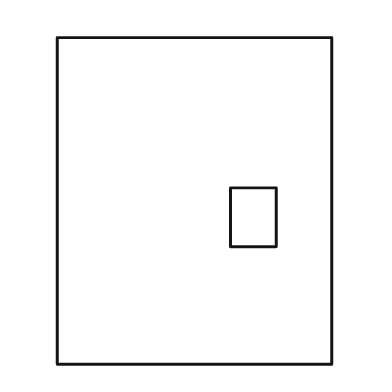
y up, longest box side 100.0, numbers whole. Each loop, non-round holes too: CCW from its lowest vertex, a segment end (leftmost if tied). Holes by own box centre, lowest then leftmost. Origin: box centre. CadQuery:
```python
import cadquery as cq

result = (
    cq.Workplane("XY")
    .moveTo(-42.0, -50.0)
    .lineTo(42.0, -50.0)
    .lineTo(42.0, 50.0)
    .lineTo(-42.0, 50.0)
    .close()
    .moveTo(11.0, -14.0)
    .lineTo(25.0, -14.0)
    .lineTo(25.0, 4.0)
    .lineTo(11.0, 4.0)
    .close()
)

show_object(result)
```